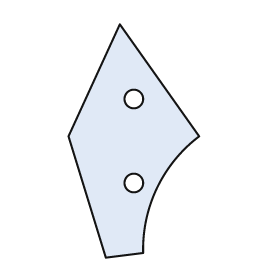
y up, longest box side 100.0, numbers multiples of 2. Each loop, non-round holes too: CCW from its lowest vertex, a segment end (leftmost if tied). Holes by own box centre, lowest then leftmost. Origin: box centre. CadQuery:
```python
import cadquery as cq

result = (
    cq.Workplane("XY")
    .moveTo(-12.0, -50.0)
    .lineTo(4.0, -48.0)
    .threePointArc((10.0, -20.0), (28.0, 2.0))
    .lineTo(-6.0, 50.0)
    .lineTo(-28.0, 2.0)
    .close()
    .moveTo(0.0, -18.0)
    .circle(4.0)
    .moveTo(0.0, 18.0)
    .circle(4.0)
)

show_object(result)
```